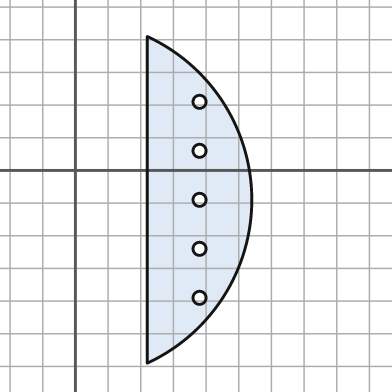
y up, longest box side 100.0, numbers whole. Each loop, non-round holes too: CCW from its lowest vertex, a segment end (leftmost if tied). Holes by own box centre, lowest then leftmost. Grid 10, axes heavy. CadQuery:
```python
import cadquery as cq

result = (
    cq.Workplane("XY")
    .moveTo(22.0, -59.0)
    .threePointArc((54.0, -9.0), (22.0, 41.0))
    .close()
    .moveTo(38.0, -39.0)
    .circle(2.0)
    .moveTo(38.0, -24.0)
    .circle(2.0)
    .moveTo(38.0, -9.0)
    .circle(2.0)
    .moveTo(38.0, 6.0)
    .circle(2.0)
    .moveTo(38.0, 21.0)
    .circle(2.0)
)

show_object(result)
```